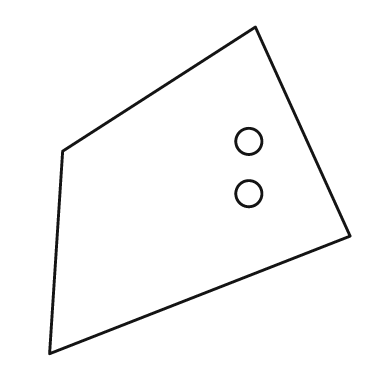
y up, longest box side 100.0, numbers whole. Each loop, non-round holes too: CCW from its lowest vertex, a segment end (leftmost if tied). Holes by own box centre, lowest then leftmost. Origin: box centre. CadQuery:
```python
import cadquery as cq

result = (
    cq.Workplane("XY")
    .moveTo(-46.0, -50.0)
    .lineTo(46.0, -14.0)
    .lineTo(17.0, 50.0)
    .lineTo(-42.0, 12.0)
    .close()
    .moveTo(15.0, -1.0)
    .circle(4.0)
    .moveTo(15.0, 15.0)
    .circle(4.0)
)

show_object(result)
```